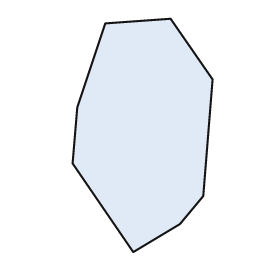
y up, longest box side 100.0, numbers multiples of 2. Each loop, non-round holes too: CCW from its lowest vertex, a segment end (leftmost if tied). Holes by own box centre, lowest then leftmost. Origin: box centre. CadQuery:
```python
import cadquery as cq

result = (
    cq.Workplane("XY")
    .moveTo(-4.0, -50.0)
    .lineTo(16.0, -38.0)
    .lineTo(26.0, -26.0)
    .lineTo(30.0, 24.0)
    .lineTo(12.0, 50.0)
    .lineTo(-16.0, 48.0)
    .lineTo(-28.0, 12.0)
    .lineTo(-30.0, -12.0)
    .close()
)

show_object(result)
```